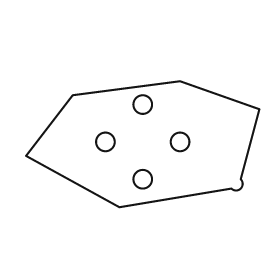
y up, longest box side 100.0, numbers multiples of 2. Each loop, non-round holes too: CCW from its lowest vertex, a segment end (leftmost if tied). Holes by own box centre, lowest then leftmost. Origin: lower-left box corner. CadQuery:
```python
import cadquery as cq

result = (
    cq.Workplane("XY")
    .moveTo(40.0, 0.0)
    .lineTo(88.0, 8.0)
    .threePointArc((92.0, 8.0), (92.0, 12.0))
    .lineTo(100.0, 42.0)
    .lineTo(66.0, 54.0)
    .lineTo(20.0, 48.0)
    .lineTo(0.0, 22.0)
    .close()
    .moveTo(50.0, 12.0)
    .circle(4.0)
    .moveTo(34.0, 28.0)
    .circle(4.0)
    .moveTo(66.0, 28.0)
    .circle(4.0)
    .moveTo(50.0, 44.0)
    .circle(4.0)
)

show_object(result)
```